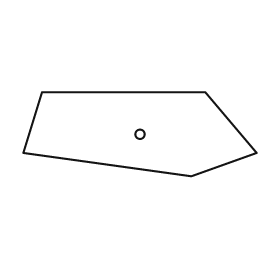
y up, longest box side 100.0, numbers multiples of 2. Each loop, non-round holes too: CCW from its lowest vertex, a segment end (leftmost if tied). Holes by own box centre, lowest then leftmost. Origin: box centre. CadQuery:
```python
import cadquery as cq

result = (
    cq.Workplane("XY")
    .moveTo(22.0, -18.0)
    .lineTo(50.0, -8.0)
    .lineTo(28.0, 18.0)
    .lineTo(-42.0, 18.0)
    .lineTo(-50.0, -8.0)
    .close()
    .moveTo(0.0, 0.0)
    .circle(2.0)
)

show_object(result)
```